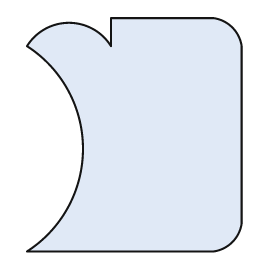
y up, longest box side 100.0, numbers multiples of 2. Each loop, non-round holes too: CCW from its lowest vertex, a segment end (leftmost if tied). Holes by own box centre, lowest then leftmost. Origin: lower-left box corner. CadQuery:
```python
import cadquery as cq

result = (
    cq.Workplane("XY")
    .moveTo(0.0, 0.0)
    .lineTo(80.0, 0.0)
    .threePointArc((88.0, 4.0), (92.0, 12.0))
    .lineTo(92.0, 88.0)
    .threePointArc((88.0, 96.0), (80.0, 100.0))
    .lineTo(36.0, 100.0)
    .lineTo(36.0, 88.0)
    .threePointArc((18.0, 98.0), (0.0, 88.0))
    .threePointArc((24.0, 44.0), (0.0, 0.0))
    .close()
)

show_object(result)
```